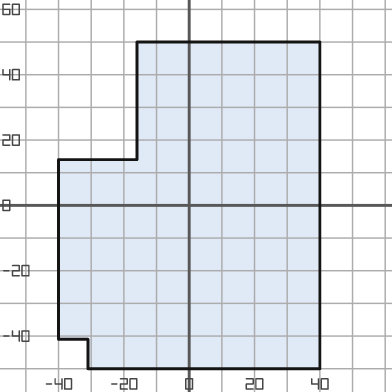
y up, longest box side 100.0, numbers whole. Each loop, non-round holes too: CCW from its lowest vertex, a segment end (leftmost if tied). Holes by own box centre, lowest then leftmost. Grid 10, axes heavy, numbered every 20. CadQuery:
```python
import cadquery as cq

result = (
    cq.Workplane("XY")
    .moveTo(-31.0, -50.0)
    .lineTo(40.0, -50.0)
    .lineTo(40.0, 50.0)
    .lineTo(-16.0, 50.0)
    .lineTo(-16.0, 14.0)
    .lineTo(-40.0, 14.0)
    .lineTo(-40.0, -41.0)
    .lineTo(-31.0, -41.0)
    .close()
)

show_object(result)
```